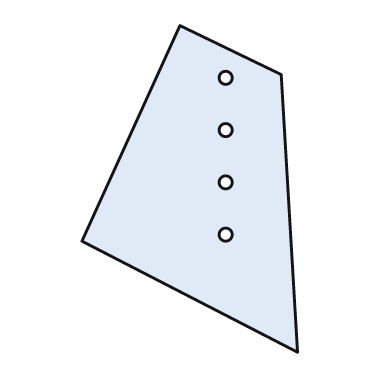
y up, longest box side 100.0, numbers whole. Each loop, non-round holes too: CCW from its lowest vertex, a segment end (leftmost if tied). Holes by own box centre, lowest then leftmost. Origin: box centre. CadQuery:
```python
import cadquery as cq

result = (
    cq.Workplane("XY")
    .moveTo(33.0, -50.0)
    .lineTo(28.0, 35.0)
    .lineTo(-3.0, 50.0)
    .lineTo(-33.0, -16.0)
    .close()
    .moveTo(11.0, -14.0)
    .circle(2.0)
    .moveTo(11.0, 2.0)
    .circle(2.0)
    .moveTo(11.0, 18.0)
    .circle(2.0)
    .moveTo(11.0, 34.0)
    .circle(2.0)
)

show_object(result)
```